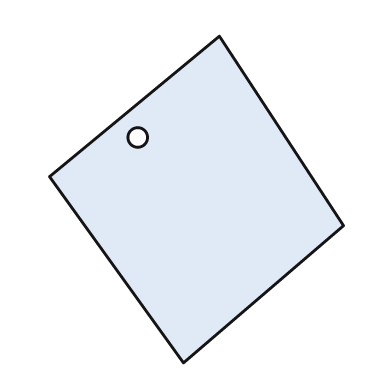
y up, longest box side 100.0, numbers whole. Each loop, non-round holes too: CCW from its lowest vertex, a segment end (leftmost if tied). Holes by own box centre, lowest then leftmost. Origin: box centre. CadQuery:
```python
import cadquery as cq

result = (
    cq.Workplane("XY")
    .moveTo(-4.0, -50.0)
    .lineTo(45.0, -8.0)
    .lineTo(7.0, 50.0)
    .lineTo(-45.0, 7.0)
    .close()
    .moveTo(-18.0, 19.0)
    .circle(3.0)
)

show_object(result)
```